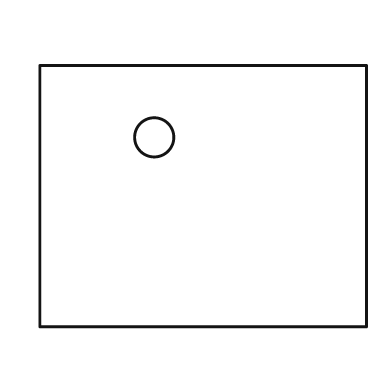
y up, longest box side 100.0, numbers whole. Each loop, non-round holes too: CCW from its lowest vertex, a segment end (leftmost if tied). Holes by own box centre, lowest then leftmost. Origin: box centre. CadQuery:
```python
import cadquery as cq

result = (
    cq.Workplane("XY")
    .moveTo(-50.0, -40.0)
    .lineTo(50.0, -40.0)
    .lineTo(50.0, 40.0)
    .lineTo(-50.0, 40.0)
    .close()
    .moveTo(-15.0, 18.0)
    .circle(6.0)
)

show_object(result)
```